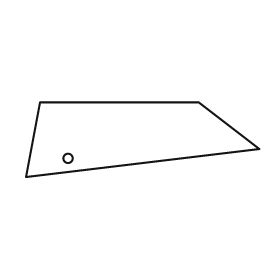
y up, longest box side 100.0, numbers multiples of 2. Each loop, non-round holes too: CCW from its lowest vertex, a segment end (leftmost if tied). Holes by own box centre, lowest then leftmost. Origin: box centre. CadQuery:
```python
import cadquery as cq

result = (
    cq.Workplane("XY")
    .moveTo(-50.0, -16.0)
    .lineTo(50.0, -4.0)
    .lineTo(24.0, 16.0)
    .lineTo(-44.0, 16.0)
    .close()
    .moveTo(-32.0, -8.0)
    .circle(2.0)
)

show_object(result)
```